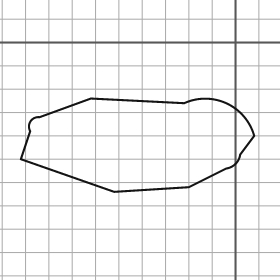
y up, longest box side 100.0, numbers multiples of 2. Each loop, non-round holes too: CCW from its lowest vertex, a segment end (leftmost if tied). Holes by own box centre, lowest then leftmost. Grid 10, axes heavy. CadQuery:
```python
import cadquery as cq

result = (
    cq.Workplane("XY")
    .moveTo(-52.0, -64.0)
    .lineTo(-20.0, -62.0)
    .lineTo(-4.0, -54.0)
    .threePointArc((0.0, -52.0), (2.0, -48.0))
    .lineTo(8.0, -40.0)
    .threePointArc((-4.0, -26.0), (-22.0, -26.0))
    .lineTo(-62.0, -24.0)
    .lineTo(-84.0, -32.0)
    .threePointArc((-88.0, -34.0), (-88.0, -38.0))
    .lineTo(-92.0, -50.0)
    .close()
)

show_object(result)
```